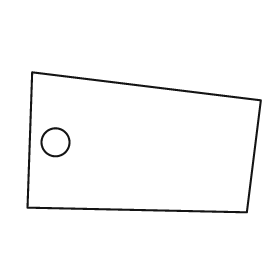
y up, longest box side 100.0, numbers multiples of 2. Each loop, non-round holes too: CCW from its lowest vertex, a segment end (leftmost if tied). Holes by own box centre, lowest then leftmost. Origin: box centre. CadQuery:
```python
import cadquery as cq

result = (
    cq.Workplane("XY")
    .moveTo(44.0, -30.0)
    .lineTo(50.0, 18.0)
    .lineTo(-48.0, 30.0)
    .lineTo(-50.0, -28.0)
    .close()
    .moveTo(-38.0, 0.0)
    .circle(6.0)
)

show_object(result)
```